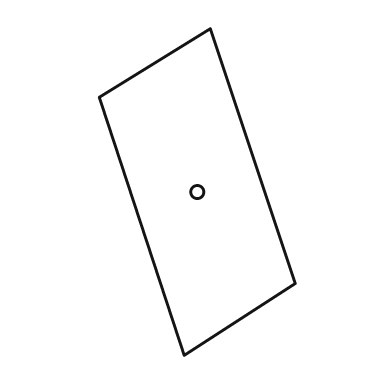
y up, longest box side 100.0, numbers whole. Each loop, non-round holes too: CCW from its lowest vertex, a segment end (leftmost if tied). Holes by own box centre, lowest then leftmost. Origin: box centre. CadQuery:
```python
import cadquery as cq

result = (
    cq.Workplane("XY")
    .moveTo(-4.0, -50.0)
    .lineTo(30.0, -28.0)
    .lineTo(4.0, 50.0)
    .lineTo(-30.0, 29.0)
    .close()
    .moveTo(0.0, 0.0)
    .circle(2.0)
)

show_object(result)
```